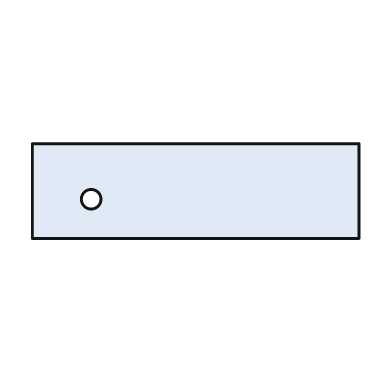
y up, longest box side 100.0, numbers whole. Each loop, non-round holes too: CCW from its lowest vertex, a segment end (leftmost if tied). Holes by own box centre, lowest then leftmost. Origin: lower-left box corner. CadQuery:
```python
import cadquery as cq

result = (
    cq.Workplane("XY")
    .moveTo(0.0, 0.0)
    .lineTo(100.0, 0.0)
    .lineTo(100.0, 29.0)
    .lineTo(0.0, 29.0)
    .close()
    .moveTo(18.0, 12.0)
    .circle(3.0)
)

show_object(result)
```